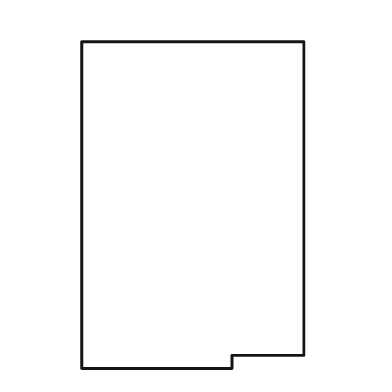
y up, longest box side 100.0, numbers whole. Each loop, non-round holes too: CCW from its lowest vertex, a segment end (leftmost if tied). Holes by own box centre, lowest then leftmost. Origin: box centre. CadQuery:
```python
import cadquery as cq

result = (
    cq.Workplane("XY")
    .moveTo(-34.0, -50.0)
    .lineTo(12.0, -50.0)
    .lineTo(12.0, -46.0)
    .lineTo(34.0, -46.0)
    .lineTo(34.0, 50.0)
    .lineTo(-34.0, 50.0)
    .close()
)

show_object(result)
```